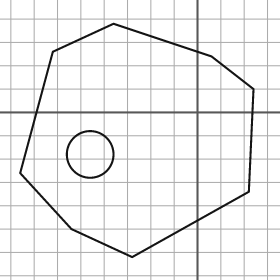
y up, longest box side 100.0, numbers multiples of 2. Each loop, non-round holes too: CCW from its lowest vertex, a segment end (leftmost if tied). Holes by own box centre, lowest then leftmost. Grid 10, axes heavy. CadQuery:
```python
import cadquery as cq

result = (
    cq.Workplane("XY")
    .moveTo(-28.0, -62.0)
    .lineTo(22.0, -34.0)
    .lineTo(24.0, 10.0)
    .lineTo(6.0, 24.0)
    .lineTo(-36.0, 38.0)
    .lineTo(-62.0, 26.0)
    .lineTo(-76.0, -26.0)
    .lineTo(-54.0, -50.0)
    .close()
    .moveTo(-46.0, -18.0)
    .circle(10.0)
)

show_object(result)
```